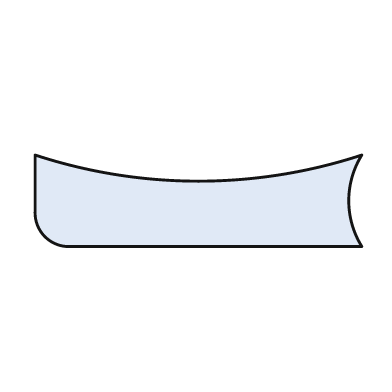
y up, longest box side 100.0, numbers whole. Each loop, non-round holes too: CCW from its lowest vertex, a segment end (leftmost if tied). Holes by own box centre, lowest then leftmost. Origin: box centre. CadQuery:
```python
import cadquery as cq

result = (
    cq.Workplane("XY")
    .moveTo(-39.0, -14.0)
    .lineTo(50.0, -14.0)
    .threePointArc((46.0, 0.0), (50.0, 14.0))
    .threePointArc((0.0, 6.0), (-50.0, 14.0))
    .lineTo(-50.0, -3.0)
    .threePointArc((-47.0, -11.0), (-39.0, -14.0))
    .close()
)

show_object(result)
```